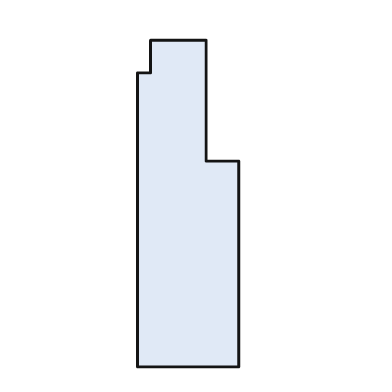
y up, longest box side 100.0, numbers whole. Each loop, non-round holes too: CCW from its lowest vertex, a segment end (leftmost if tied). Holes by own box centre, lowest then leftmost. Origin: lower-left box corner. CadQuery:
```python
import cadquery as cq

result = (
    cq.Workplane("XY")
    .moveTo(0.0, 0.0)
    .lineTo(31.0, 0.0)
    .lineTo(31.0, 63.0)
    .lineTo(21.0, 63.0)
    .lineTo(21.0, 100.0)
    .lineTo(4.0, 100.0)
    .lineTo(4.0, 90.0)
    .lineTo(0.0, 90.0)
    .close()
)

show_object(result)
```